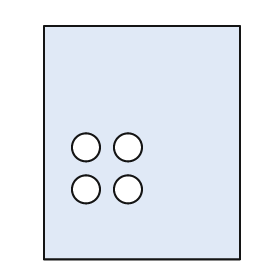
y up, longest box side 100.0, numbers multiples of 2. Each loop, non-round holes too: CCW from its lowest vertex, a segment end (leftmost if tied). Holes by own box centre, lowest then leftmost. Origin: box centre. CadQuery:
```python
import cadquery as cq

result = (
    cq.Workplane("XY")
    .moveTo(-42.0, -50.0)
    .lineTo(42.0, -50.0)
    .lineTo(42.0, 50.0)
    .lineTo(-42.0, 50.0)
    .close()
    .moveTo(-24.0, -20.0)
    .circle(6.0)
    .moveTo(-6.0, -20.0)
    .circle(6.0)
    .moveTo(-24.0, -2.0)
    .circle(6.0)
    .moveTo(-6.0, -2.0)
    .circle(6.0)
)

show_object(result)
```